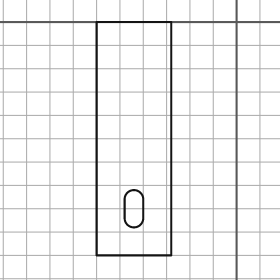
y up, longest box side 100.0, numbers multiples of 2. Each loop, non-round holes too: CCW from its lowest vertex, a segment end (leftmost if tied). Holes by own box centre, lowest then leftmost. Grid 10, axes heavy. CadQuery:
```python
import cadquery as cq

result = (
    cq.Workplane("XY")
    .moveTo(-60.0, -100.0)
    .lineTo(-28.0, -100.0)
    .lineTo(-28.0, 0.0)
    .lineTo(-60.0, 0.0)
    .close()
    .moveTo(-48.0, -84.0)
    .threePointArc((-44.0, -88.0), (-40.0, -84.0))
    .lineTo(-40.0, -76.0)
    .threePointArc((-44.0, -72.0), (-48.0, -76.0))
    .close()
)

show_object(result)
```